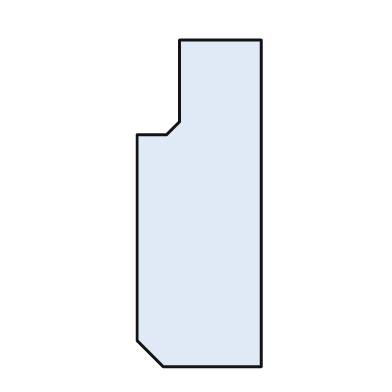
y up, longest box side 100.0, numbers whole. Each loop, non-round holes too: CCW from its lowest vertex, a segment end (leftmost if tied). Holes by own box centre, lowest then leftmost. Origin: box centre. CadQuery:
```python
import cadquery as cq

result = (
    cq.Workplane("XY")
    .moveTo(-11.0, -50.0)
    .lineTo(19.0, -50.0)
    .lineTo(19.0, 50.0)
    .lineTo(-6.0, 50.0)
    .lineTo(-6.0, 25.0)
    .lineTo(-10.0, 21.0)
    .lineTo(-19.0, 21.0)
    .lineTo(-19.0, -42.0)
    .close()
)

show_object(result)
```